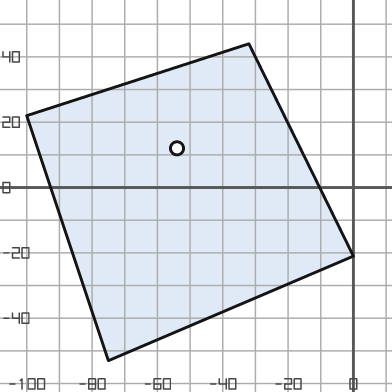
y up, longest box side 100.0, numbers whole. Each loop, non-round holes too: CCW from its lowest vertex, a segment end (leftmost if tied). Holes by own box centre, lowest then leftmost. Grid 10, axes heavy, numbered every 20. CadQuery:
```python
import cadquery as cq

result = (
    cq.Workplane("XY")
    .moveTo(-75.0, -53.0)
    .lineTo(0.0, -21.0)
    .lineTo(-32.0, 44.0)
    .lineTo(-100.0, 22.0)
    .close()
    .moveTo(-54.0, 12.0)
    .circle(2.0)
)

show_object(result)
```